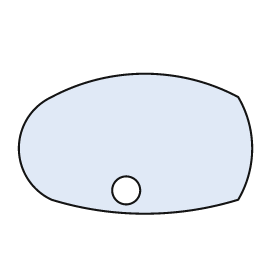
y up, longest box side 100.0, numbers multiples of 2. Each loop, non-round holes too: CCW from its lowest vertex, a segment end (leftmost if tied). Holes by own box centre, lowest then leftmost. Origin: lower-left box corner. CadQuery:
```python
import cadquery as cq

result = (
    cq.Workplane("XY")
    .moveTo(14.0, 6.0)
    .threePointArc((54.0, 0.0), (94.0, 6.0))
    .threePointArc((100.0, 28.0), (94.0, 50.0))
    .threePointArc((54.0, 60.0), (14.0, 50.0))
    .threePointArc((0.0, 28.0), (14.0, 6.0))
    .close()
    .moveTo(46.0, 10.0)
    .circle(6.0)
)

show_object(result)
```